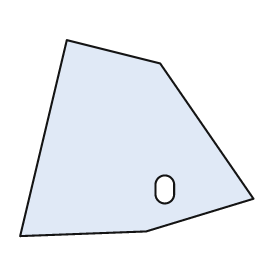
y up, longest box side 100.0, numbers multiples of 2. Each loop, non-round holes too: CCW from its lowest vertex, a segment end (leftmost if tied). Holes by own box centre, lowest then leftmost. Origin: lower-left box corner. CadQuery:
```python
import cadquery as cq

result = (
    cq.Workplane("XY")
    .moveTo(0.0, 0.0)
    .lineTo(54.0, 2.0)
    .lineTo(100.0, 16.0)
    .lineTo(60.0, 74.0)
    .lineTo(20.0, 84.0)
    .close()
    .moveTo(58.0, 18.0)
    .threePointArc((62.0, 14.0), (66.0, 18.0))
    .lineTo(66.0, 22.0)
    .threePointArc((62.0, 26.0), (58.0, 22.0))
    .close()
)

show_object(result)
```